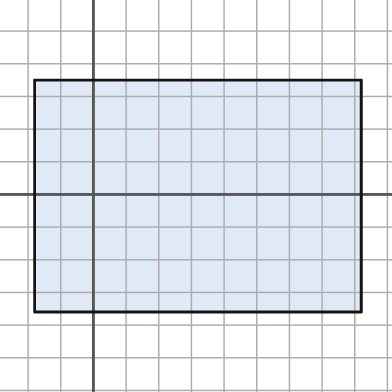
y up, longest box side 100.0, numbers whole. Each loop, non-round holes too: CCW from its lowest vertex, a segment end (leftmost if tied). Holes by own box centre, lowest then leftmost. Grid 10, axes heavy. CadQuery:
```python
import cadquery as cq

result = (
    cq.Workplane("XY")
    .moveTo(-18.0, -36.0)
    .lineTo(82.0, -36.0)
    .lineTo(82.0, 35.0)
    .lineTo(-18.0, 35.0)
    .close()
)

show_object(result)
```